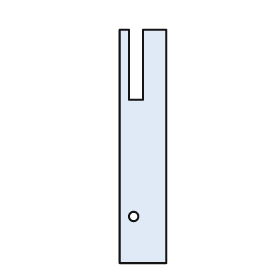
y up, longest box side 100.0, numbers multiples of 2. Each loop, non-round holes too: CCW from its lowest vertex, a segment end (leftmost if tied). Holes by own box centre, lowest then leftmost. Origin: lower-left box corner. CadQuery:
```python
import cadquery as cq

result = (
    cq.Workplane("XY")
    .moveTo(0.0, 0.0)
    .lineTo(20.0, 0.0)
    .lineTo(20.0, 100.0)
    .lineTo(10.0, 100.0)
    .lineTo(10.0, 70.0)
    .lineTo(4.0, 70.0)
    .lineTo(4.0, 100.0)
    .lineTo(0.0, 100.0)
    .close()
    .moveTo(6.0, 20.0)
    .circle(2.0)
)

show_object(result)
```